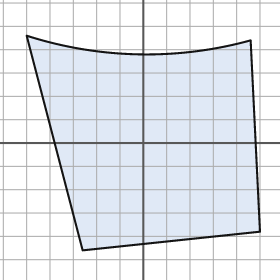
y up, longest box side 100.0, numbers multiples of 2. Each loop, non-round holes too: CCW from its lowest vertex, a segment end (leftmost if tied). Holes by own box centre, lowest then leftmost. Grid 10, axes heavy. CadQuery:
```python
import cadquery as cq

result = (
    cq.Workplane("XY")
    .moveTo(-26.0, -46.0)
    .lineTo(50.0, -38.0)
    .lineTo(46.0, 44.0)
    .threePointArc((-2.0, 38.0), (-50.0, 46.0))
    .close()
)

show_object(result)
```